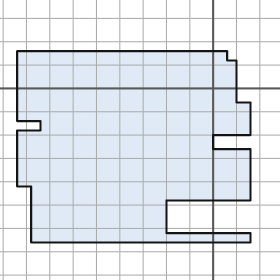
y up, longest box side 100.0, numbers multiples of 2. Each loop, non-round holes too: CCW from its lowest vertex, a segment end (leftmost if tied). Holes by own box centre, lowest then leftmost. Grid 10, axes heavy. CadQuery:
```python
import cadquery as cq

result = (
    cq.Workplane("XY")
    .moveTo(-78.0, -66.0)
    .lineTo(16.0, -66.0)
    .lineTo(16.0, -62.0)
    .lineTo(-20.0, -62.0)
    .lineTo(-20.0, -48.0)
    .lineTo(16.0, -48.0)
    .lineTo(16.0, -26.0)
    .lineTo(0.0, -26.0)
    .lineTo(0.0, -20.0)
    .lineTo(16.0, -20.0)
    .lineTo(16.0, -6.0)
    .lineTo(10.0, -6.0)
    .lineTo(10.0, 12.0)
    .lineTo(6.0, 12.0)
    .lineTo(6.0, 16.0)
    .lineTo(-84.0, 16.0)
    .lineTo(-84.0, -14.0)
    .lineTo(-74.0, -14.0)
    .lineTo(-74.0, -18.0)
    .lineTo(-84.0, -18.0)
    .lineTo(-84.0, -42.0)
    .lineTo(-78.0, -42.0)
    .close()
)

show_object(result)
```